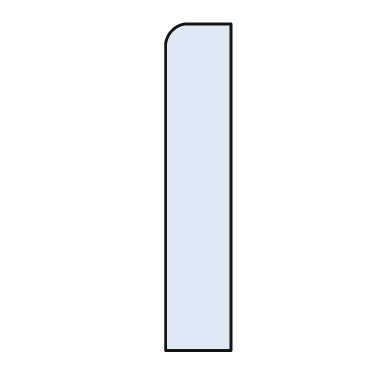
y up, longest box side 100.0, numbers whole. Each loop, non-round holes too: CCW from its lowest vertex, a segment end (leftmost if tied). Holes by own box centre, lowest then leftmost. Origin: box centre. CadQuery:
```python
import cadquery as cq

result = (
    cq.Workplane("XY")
    .moveTo(-10.0, -50.0)
    .lineTo(10.0, -50.0)
    .lineTo(10.0, 50.0)
    .lineTo(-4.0, 50.0)
    .threePointArc((-8.0, 48.0), (-10.0, 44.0))
    .close()
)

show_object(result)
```